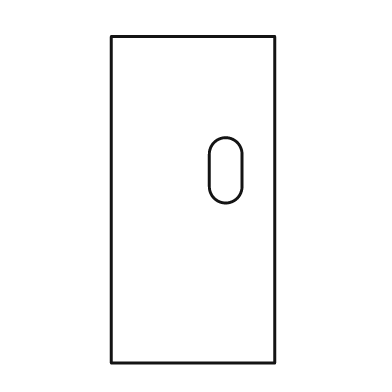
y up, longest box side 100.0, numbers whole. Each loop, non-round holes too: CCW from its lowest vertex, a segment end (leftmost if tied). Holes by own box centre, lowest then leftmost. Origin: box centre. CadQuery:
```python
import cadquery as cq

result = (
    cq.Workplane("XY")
    .moveTo(-25.0, -50.0)
    .lineTo(25.0, -50.0)
    .lineTo(25.0, 50.0)
    .lineTo(-25.0, 50.0)
    .close()
    .moveTo(5.0, 4.0)
    .threePointArc((10.0, -1.0), (15.0, 4.0))
    .lineTo(15.0, 14.0)
    .threePointArc((10.0, 19.0), (5.0, 14.0))
    .close()
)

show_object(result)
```